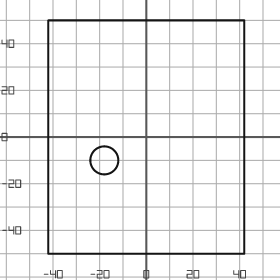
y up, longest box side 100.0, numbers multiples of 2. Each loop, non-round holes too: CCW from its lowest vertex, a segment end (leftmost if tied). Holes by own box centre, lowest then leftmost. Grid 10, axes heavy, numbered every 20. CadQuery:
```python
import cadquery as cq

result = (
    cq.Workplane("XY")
    .moveTo(-42.0, -50.0)
    .lineTo(42.0, -50.0)
    .lineTo(42.0, 50.0)
    .lineTo(-42.0, 50.0)
    .close()
    .moveTo(-18.0, -10.0)
    .circle(6.0)
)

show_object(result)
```